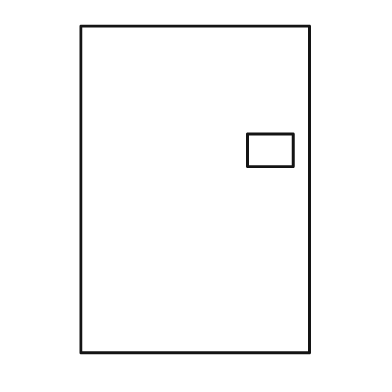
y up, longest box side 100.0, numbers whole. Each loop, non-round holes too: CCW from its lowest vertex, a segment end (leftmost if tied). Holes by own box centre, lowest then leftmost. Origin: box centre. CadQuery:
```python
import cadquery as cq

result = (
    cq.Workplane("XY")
    .moveTo(-35.0, -50.0)
    .lineTo(35.0, -50.0)
    .lineTo(35.0, 50.0)
    .lineTo(-35.0, 50.0)
    .close()
    .moveTo(16.0, 7.0)
    .lineTo(30.0, 7.0)
    .lineTo(30.0, 17.0)
    .lineTo(16.0, 17.0)
    .close()
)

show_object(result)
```